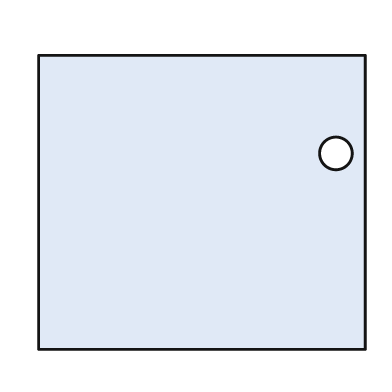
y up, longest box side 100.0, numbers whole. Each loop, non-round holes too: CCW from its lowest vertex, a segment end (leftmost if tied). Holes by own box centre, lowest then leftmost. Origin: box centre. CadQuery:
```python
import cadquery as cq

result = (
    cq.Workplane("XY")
    .moveTo(-50.0, -45.0)
    .lineTo(50.0, -45.0)
    .lineTo(50.0, 45.0)
    .lineTo(-50.0, 45.0)
    .close()
    .moveTo(41.0, 15.0)
    .circle(5.0)
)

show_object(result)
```